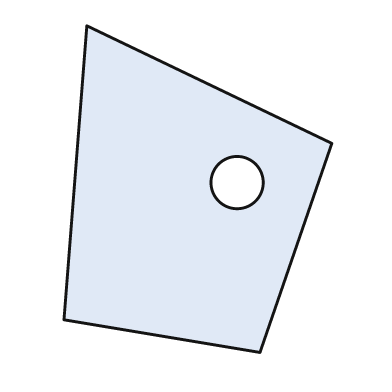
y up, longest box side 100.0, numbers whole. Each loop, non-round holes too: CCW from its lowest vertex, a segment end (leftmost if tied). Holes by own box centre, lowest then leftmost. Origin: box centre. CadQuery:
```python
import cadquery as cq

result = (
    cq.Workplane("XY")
    .moveTo(19.0, -50.0)
    .lineTo(41.0, 14.0)
    .lineTo(-34.0, 50.0)
    .lineTo(-41.0, -40.0)
    .close()
    .moveTo(12.0, 2.0)
    .circle(8.0)
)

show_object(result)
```